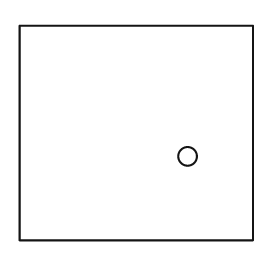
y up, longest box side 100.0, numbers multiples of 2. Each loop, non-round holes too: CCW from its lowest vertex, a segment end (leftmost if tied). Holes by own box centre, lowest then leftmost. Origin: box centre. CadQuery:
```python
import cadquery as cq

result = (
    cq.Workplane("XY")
    .moveTo(-50.0, -46.0)
    .lineTo(50.0, -46.0)
    .lineTo(50.0, 46.0)
    .lineTo(-50.0, 46.0)
    .close()
    .moveTo(22.0, -10.0)
    .circle(4.0)
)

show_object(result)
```